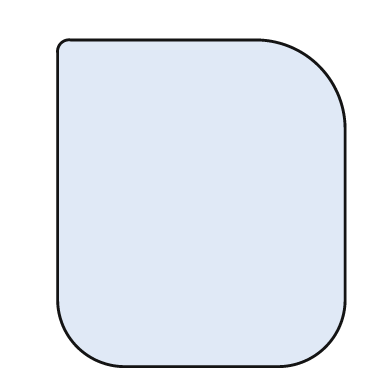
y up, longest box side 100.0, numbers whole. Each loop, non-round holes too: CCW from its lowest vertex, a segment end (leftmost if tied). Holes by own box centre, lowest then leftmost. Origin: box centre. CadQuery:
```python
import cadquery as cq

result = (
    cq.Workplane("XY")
    .moveTo(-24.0, -50.0)
    .lineTo(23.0, -50.0)
    .threePointArc((38.0, -44.0), (44.0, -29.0))
    .lineTo(44.0, 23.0)
    .threePointArc((36.0, 42.0), (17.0, 50.0))
    .lineTo(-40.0, 50.0)
    .threePointArc((-43.0, 49.0), (-44.0, 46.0))
    .lineTo(-44.0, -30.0)
    .threePointArc((-38.0, -44.0), (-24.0, -50.0))
    .close()
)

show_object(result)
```